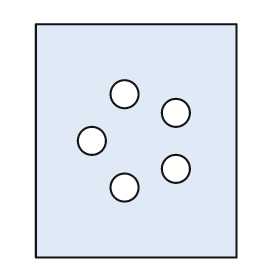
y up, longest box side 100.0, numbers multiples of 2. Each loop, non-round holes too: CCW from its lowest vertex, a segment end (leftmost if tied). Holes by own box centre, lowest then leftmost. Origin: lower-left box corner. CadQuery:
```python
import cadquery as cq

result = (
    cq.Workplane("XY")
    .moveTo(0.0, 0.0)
    .lineTo(86.0, 0.0)
    .lineTo(86.0, 100.0)
    .lineTo(0.0, 100.0)
    .close()
    .moveTo(38.0, 30.0)
    .circle(6.0)
    .moveTo(60.0, 38.0)
    .circle(6.0)
    .moveTo(24.0, 50.0)
    .circle(6.0)
    .moveTo(60.0, 62.0)
    .circle(6.0)
    .moveTo(38.0, 70.0)
    .circle(6.0)
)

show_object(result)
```